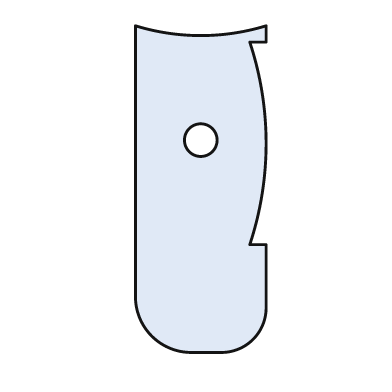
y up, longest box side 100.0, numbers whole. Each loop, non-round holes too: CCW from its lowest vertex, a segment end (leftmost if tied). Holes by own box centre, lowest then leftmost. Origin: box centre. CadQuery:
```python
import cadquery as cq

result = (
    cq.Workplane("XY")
    .moveTo(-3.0, -50.0)
    .lineTo(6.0, -50.0)
    .threePointArc((16.0, -46.0), (20.0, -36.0))
    .lineTo(20.0, -17.0)
    .lineTo(15.0, -17.0)
    .threePointArc((20.0, 14.0), (15.0, 45.0))
    .lineTo(20.0, 45.0)
    .lineTo(20.0, 50.0)
    .threePointArc((0.0, 47.0), (-20.0, 50.0))
    .lineTo(-20.0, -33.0)
    .threePointArc((-15.0, -45.0), (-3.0, -50.0))
    .close()
    .moveTo(0.0, 15.0)
    .circle(5.0)
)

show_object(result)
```